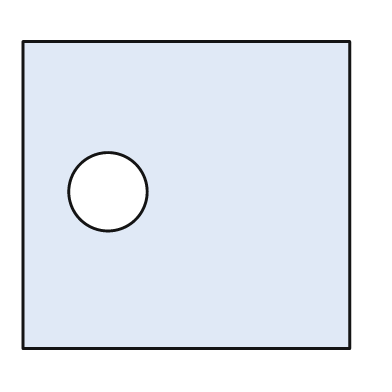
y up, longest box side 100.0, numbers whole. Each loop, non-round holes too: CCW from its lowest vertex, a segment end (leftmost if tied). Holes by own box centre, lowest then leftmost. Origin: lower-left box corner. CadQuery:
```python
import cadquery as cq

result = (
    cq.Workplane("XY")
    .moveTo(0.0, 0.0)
    .lineTo(100.0, 0.0)
    .lineTo(100.0, 94.0)
    .lineTo(0.0, 94.0)
    .close()
    .moveTo(26.0, 48.0)
    .circle(12.0)
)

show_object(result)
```